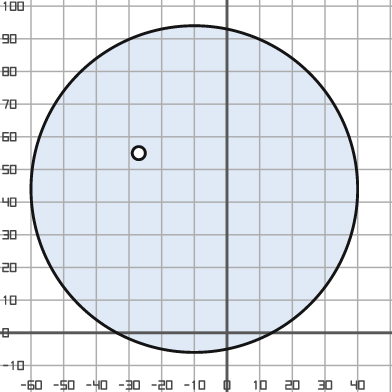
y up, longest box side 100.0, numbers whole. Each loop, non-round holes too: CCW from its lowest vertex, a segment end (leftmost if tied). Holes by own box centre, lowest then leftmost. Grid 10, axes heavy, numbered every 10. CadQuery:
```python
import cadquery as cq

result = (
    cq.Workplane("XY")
    .moveTo(-10.0, 44.0)
    .circle(50.0)
    .moveTo(-27.0, 55.0)
    .circle(2.0)
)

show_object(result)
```